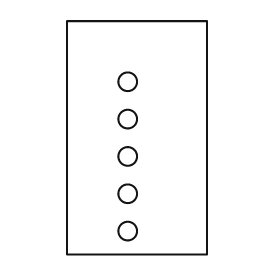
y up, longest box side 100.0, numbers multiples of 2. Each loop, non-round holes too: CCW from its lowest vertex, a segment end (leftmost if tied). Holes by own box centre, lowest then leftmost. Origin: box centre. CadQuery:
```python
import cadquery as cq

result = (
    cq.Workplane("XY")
    .moveTo(-30.0, -50.0)
    .lineTo(30.0, -50.0)
    .lineTo(30.0, 50.0)
    .lineTo(-30.0, 50.0)
    .close()
    .moveTo(-4.0, -40.0)
    .circle(4.0)
    .moveTo(-4.0, -24.0)
    .circle(4.0)
    .moveTo(-4.0, -8.0)
    .circle(4.0)
    .moveTo(-4.0, 8.0)
    .circle(4.0)
    .moveTo(-4.0, 24.0)
    .circle(4.0)
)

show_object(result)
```